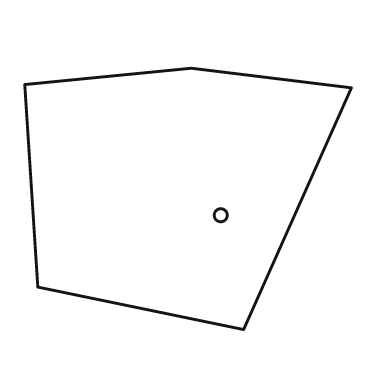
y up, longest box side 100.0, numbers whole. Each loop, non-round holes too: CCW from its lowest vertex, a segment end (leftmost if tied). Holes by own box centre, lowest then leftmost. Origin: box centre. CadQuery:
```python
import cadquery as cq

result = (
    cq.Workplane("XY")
    .moveTo(17.0, -40.0)
    .lineTo(50.0, 34.0)
    .lineTo(1.0, 40.0)
    .lineTo(-50.0, 35.0)
    .lineTo(-46.0, -27.0)
    .close()
    .moveTo(10.0, -5.0)
    .circle(2.0)
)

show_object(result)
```